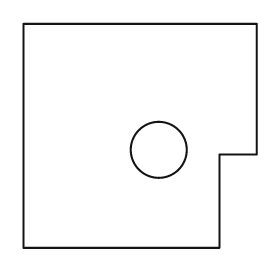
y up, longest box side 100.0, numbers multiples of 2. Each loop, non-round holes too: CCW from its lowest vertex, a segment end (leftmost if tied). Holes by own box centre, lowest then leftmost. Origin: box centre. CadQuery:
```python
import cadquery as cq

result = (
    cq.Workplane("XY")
    .moveTo(-50.0, -48.0)
    .lineTo(34.0, -48.0)
    .lineTo(34.0, -8.0)
    .lineTo(50.0, -8.0)
    .lineTo(50.0, 48.0)
    .lineTo(-50.0, 48.0)
    .close()
    .moveTo(8.0, -6.0)
    .circle(12.0)
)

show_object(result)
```